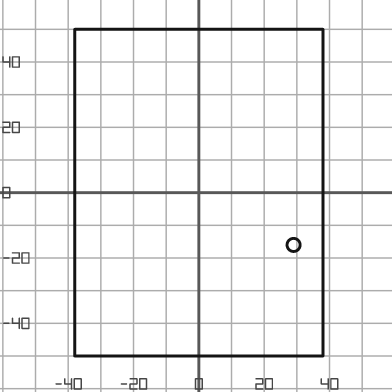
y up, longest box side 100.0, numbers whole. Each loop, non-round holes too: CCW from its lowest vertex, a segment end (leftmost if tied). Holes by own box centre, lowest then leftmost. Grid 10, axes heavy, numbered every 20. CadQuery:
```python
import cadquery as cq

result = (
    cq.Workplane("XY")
    .moveTo(-38.0, -50.0)
    .lineTo(38.0, -50.0)
    .lineTo(38.0, 50.0)
    .lineTo(-38.0, 50.0)
    .close()
    .moveTo(29.0, -16.0)
    .circle(2.0)
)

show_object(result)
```